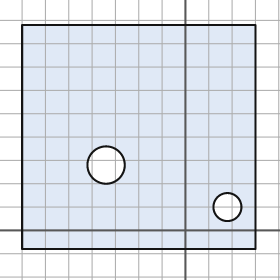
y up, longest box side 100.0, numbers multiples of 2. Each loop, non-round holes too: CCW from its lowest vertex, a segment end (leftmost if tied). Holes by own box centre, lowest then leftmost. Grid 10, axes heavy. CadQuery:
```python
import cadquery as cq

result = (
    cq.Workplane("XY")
    .moveTo(-70.0, -8.0)
    .lineTo(30.0, -8.0)
    .lineTo(30.0, 88.0)
    .lineTo(-70.0, 88.0)
    .close()
    .moveTo(18.0, 10.0)
    .circle(6.0)
    .moveTo(-34.0, 28.0)
    .circle(8.0)
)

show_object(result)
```